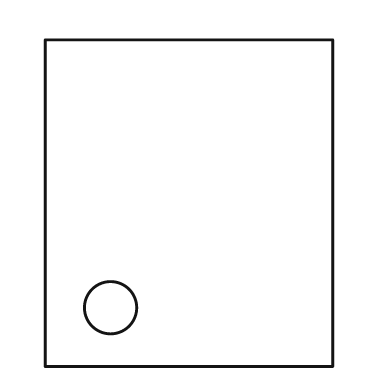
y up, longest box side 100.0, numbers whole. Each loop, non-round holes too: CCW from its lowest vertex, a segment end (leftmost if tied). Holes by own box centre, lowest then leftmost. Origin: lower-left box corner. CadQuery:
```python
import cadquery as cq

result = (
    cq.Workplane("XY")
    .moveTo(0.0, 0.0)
    .lineTo(88.0, 0.0)
    .lineTo(88.0, 100.0)
    .lineTo(0.0, 100.0)
    .close()
    .moveTo(20.0, 18.0)
    .circle(8.0)
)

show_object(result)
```